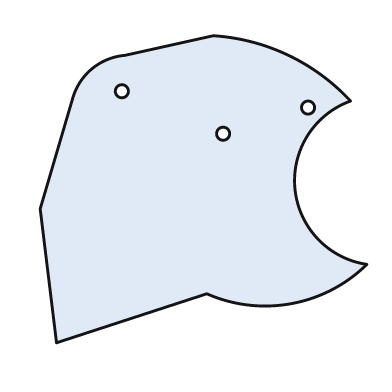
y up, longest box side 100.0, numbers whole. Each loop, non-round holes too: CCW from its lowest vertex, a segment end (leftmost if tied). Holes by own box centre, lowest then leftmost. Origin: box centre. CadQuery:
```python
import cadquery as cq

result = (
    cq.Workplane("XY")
    .moveTo(-45.0, -47.0)
    .lineTo(1.0, -32.0)
    .threePointArc((27.0, -35.0), (50.0, -23.0))
    .threePointArc((28.0, 0.0), (45.0, 27.0))
    .threePointArc((26.0, 41.0), (3.0, 47.0))
    .lineTo(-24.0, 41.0)
    .threePointArc((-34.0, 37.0), (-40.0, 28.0))
    .lineTo(-50.0, -6.0)
    .close()
    .moveTo(6.0, 17.0)
    .circle(2.0)
    .moveTo(32.0, 25.0)
    .circle(2.0)
    .moveTo(-25.0, 30.0)
    .circle(2.0)
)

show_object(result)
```